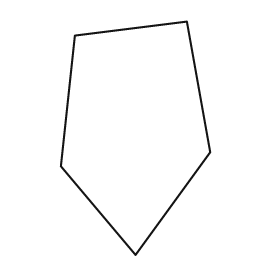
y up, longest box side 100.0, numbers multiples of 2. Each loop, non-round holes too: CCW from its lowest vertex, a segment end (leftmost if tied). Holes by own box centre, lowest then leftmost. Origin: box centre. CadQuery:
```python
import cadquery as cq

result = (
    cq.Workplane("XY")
    .moveTo(0.0, -50.0)
    .lineTo(32.0, -6.0)
    .lineTo(22.0, 50.0)
    .lineTo(-26.0, 44.0)
    .lineTo(-32.0, -12.0)
    .close()
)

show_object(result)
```